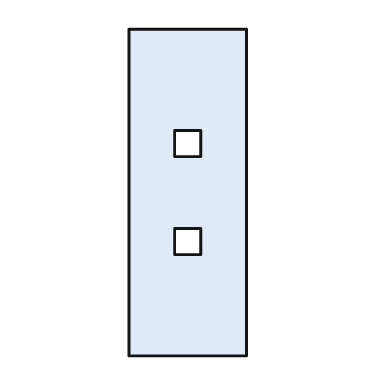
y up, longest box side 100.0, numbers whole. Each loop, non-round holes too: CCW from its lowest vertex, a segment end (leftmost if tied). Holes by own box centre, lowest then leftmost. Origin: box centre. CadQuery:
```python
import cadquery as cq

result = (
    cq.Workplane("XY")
    .moveTo(-18.0, -50.0)
    .lineTo(18.0, -50.0)
    .lineTo(18.0, 50.0)
    .lineTo(-18.0, 50.0)
    .close()
    .moveTo(-4.0, -19.0)
    .lineTo(4.0, -19.0)
    .lineTo(4.0, -11.0)
    .lineTo(-4.0, -11.0)
    .close()
    .moveTo(-4.0, 11.0)
    .lineTo(4.0, 11.0)
    .lineTo(4.0, 19.0)
    .lineTo(-4.0, 19.0)
    .close()
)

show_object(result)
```